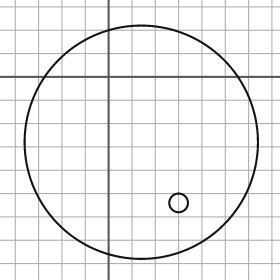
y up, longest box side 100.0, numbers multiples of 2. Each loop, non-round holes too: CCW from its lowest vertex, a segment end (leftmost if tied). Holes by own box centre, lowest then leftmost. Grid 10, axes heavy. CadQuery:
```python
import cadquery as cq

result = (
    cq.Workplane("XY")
    .moveTo(14.0, -28.0)
    .circle(50.0)
    .moveTo(30.0, -54.0)
    .circle(4.0)
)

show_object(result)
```